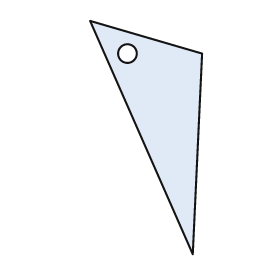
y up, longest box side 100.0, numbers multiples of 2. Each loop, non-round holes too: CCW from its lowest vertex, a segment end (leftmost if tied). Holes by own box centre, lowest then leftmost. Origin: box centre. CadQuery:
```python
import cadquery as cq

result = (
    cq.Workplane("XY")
    .moveTo(20.0, -50.0)
    .lineTo(24.0, 36.0)
    .lineTo(-24.0, 50.0)
    .close()
    .moveTo(-8.0, 36.0)
    .circle(4.0)
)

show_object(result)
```